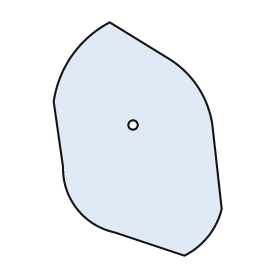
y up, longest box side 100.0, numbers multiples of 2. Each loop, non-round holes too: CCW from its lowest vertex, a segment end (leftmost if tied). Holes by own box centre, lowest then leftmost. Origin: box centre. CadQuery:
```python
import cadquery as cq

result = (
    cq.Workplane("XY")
    .moveTo(20.0, -50.0)
    .threePointArc((30.0, -42.0), (36.0, -30.0))
    .lineTo(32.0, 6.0)
    .threePointArc((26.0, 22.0), (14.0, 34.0))
    .lineTo(-12.0, 50.0)
    .threePointArc((-28.0, 36.0), (-36.0, 16.0))
    .lineTo(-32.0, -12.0)
    .threePointArc((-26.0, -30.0), (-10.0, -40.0))
    .close()
    .moveTo(-2.0, 6.0)
    .circle(2.0)
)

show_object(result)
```